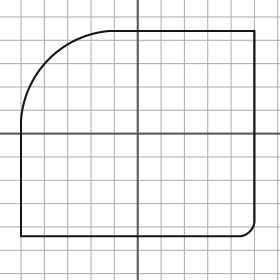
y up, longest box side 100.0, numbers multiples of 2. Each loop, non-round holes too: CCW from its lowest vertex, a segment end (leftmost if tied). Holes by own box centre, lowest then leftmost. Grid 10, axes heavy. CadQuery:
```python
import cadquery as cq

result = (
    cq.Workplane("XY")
    .moveTo(-50.0, -44.0)
    .lineTo(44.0, -44.0)
    .threePointArc((48.0, -42.0), (50.0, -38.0))
    .lineTo(50.0, 44.0)
    .lineTo(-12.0, 44.0)
    .threePointArc((-38.0, 32.0), (-50.0, 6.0))
    .close()
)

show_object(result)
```